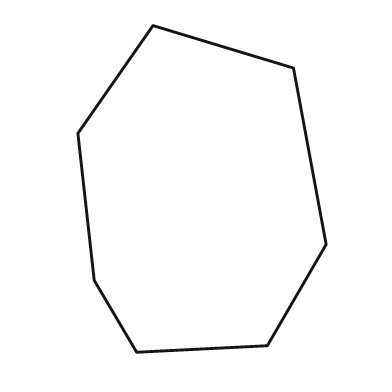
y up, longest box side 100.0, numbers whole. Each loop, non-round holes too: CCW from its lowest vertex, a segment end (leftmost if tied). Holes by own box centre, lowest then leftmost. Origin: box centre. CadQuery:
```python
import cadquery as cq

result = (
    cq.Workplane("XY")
    .moveTo(-20.0, -50.0)
    .lineTo(20.0, -48.0)
    .lineTo(38.0, -17.0)
    .lineTo(28.0, 37.0)
    .lineTo(-15.0, 50.0)
    .lineTo(-38.0, 17.0)
    .lineTo(-33.0, -28.0)
    .close()
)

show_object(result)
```